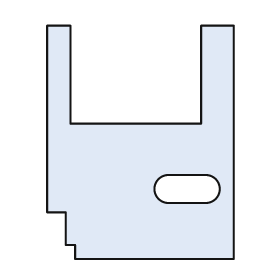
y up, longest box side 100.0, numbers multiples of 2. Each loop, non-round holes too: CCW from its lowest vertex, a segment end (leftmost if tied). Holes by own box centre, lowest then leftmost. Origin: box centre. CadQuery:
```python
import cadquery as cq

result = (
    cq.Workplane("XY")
    .moveTo(-28.0, -50.0)
    .lineTo(40.0, -50.0)
    .lineTo(40.0, 50.0)
    .lineTo(26.0, 50.0)
    .lineTo(26.0, 8.0)
    .lineTo(-30.0, 8.0)
    .lineTo(-30.0, 50.0)
    .lineTo(-40.0, 50.0)
    .lineTo(-40.0, -30.0)
    .lineTo(-32.0, -30.0)
    .lineTo(-32.0, -44.0)
    .lineTo(-28.0, -44.0)
    .close()
    .moveTo(12.0, -26.0)
    .lineTo(28.0, -26.0)
    .threePointArc((34.0, -20.0), (28.0, -14.0))
    .lineTo(12.0, -14.0)
    .threePointArc((6.0, -20.0), (12.0, -26.0))
    .close()
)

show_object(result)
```